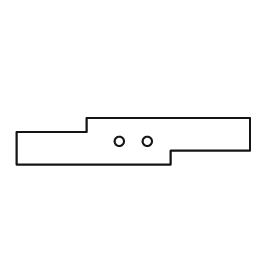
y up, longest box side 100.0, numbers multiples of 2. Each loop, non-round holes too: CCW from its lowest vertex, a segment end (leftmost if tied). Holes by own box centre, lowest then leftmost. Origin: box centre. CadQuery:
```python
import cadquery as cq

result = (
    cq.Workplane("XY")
    .moveTo(-50.0, -10.0)
    .lineTo(16.0, -10.0)
    .lineTo(16.0, -4.0)
    .lineTo(50.0, -4.0)
    .lineTo(50.0, 10.0)
    .lineTo(-20.0, 10.0)
    .lineTo(-20.0, 4.0)
    .lineTo(-50.0, 4.0)
    .close()
    .moveTo(-6.0, 0.0)
    .circle(2.0)
    .moveTo(6.0, 0.0)
    .circle(2.0)
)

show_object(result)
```